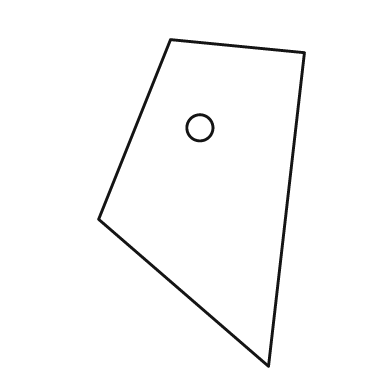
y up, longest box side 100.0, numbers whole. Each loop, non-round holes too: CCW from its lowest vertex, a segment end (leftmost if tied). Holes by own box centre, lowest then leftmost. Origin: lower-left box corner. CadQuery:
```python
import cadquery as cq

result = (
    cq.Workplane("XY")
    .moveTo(52.0, 0.0)
    .lineTo(63.0, 96.0)
    .lineTo(22.0, 100.0)
    .lineTo(0.0, 45.0)
    .close()
    .moveTo(31.0, 73.0)
    .circle(4.0)
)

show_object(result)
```